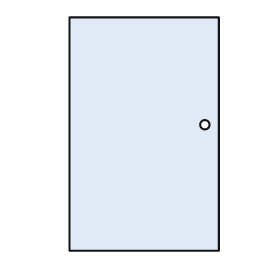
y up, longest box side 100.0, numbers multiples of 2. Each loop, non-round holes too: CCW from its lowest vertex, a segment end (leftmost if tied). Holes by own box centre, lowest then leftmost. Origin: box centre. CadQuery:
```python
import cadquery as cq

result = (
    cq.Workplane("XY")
    .moveTo(-32.0, -50.0)
    .lineTo(32.0, -50.0)
    .lineTo(32.0, 50.0)
    .lineTo(-32.0, 50.0)
    .close()
    .moveTo(26.0, 4.0)
    .circle(2.0)
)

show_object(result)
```